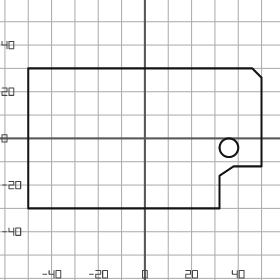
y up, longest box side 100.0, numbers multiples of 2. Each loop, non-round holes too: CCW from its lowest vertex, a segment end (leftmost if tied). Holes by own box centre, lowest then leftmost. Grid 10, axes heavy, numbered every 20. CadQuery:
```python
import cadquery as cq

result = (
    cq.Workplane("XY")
    .moveTo(-50.0, -30.0)
    .lineTo(32.0, -30.0)
    .lineTo(32.0, -16.0)
    .lineTo(38.0, -12.0)
    .lineTo(50.0, -12.0)
    .lineTo(50.0, 26.0)
    .lineTo(46.0, 30.0)
    .lineTo(-50.0, 30.0)
    .close()
    .moveTo(36.0, -4.0)
    .circle(4.0)
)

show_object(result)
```